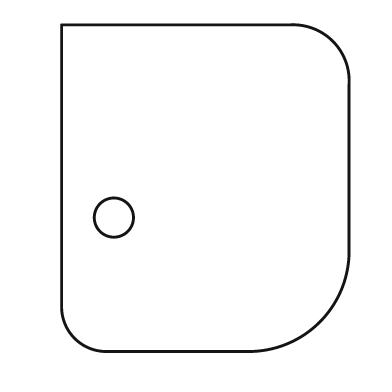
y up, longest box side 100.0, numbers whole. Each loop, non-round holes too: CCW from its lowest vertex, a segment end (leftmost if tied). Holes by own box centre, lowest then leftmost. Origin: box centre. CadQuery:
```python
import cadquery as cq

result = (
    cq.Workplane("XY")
    .moveTo(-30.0, -50.0)
    .lineTo(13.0, -50.0)
    .threePointArc((35.0, -41.0), (44.0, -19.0))
    .lineTo(44.0, 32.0)
    .threePointArc((39.0, 45.0), (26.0, 50.0))
    .lineTo(-44.0, 50.0)
    .lineTo(-44.0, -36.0)
    .threePointArc((-40.0, -46.0), (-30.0, -50.0))
    .close()
    .moveTo(-28.0, -9.0)
    .circle(6.0)
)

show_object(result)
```